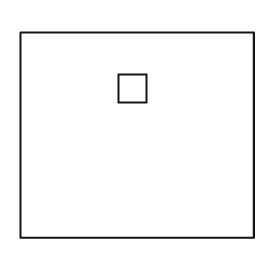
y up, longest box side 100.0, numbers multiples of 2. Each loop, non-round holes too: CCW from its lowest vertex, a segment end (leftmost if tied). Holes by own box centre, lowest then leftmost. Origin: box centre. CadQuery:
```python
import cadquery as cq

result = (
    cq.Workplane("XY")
    .moveTo(-50.0, -44.0)
    .lineTo(50.0, -44.0)
    .lineTo(50.0, 44.0)
    .lineTo(-50.0, 44.0)
    .close()
    .moveTo(-8.0, 14.0)
    .lineTo(4.0, 14.0)
    .lineTo(4.0, 26.0)
    .lineTo(-8.0, 26.0)
    .close()
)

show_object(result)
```